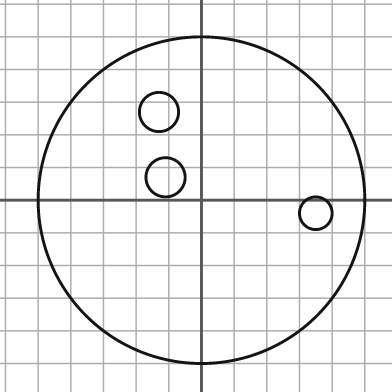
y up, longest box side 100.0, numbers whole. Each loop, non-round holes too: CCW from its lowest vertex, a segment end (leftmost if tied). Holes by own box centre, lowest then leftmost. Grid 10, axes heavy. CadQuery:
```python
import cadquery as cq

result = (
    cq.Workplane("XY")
    .moveTo(0.0, 0.0)
    .circle(50.0)
    .moveTo(35.0, -4.0)
    .circle(5.0)
    .moveTo(-11.0, 7.0)
    .circle(6.0)
    .moveTo(-13.0, 27.0)
    .circle(6.0)
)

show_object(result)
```